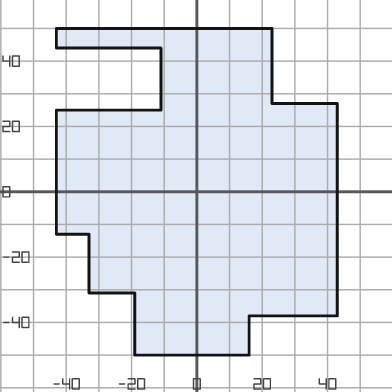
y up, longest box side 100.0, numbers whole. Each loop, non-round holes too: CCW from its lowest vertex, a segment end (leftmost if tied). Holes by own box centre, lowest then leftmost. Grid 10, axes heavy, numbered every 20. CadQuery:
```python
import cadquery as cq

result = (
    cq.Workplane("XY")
    .moveTo(-19.0, -50.0)
    .lineTo(16.0, -50.0)
    .lineTo(16.0, -38.0)
    .lineTo(43.0, -38.0)
    .lineTo(43.0, 27.0)
    .lineTo(23.0, 27.0)
    .lineTo(23.0, 50.0)
    .lineTo(-43.0, 50.0)
    .lineTo(-43.0, 44.0)
    .lineTo(-11.0, 44.0)
    .lineTo(-11.0, 25.0)
    .lineTo(-43.0, 25.0)
    .lineTo(-43.0, -13.0)
    .lineTo(-33.0, -13.0)
    .lineTo(-33.0, -31.0)
    .lineTo(-19.0, -31.0)
    .close()
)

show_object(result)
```